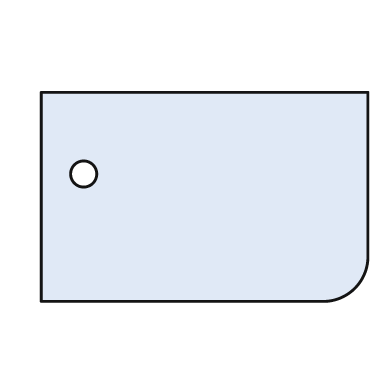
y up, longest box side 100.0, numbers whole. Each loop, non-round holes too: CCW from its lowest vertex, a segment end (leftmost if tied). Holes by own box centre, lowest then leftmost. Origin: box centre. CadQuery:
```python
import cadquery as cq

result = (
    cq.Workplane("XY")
    .moveTo(-50.0, -32.0)
    .lineTo(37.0, -32.0)
    .threePointArc((46.0, -28.0), (50.0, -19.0))
    .lineTo(50.0, 32.0)
    .lineTo(-50.0, 32.0)
    .close()
    .moveTo(-37.0, 7.0)
    .circle(4.0)
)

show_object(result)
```